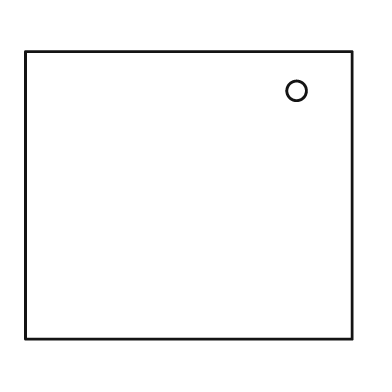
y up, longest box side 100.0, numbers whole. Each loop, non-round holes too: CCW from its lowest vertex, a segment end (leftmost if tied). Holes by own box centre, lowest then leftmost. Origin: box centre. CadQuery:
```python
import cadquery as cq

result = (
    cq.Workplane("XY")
    .moveTo(-50.0, -44.0)
    .lineTo(50.0, -44.0)
    .lineTo(50.0, 44.0)
    .lineTo(-50.0, 44.0)
    .close()
    .moveTo(33.0, 32.0)
    .circle(3.0)
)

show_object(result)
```